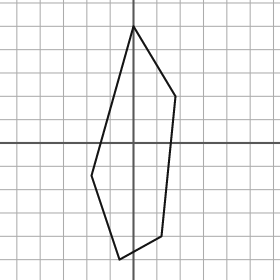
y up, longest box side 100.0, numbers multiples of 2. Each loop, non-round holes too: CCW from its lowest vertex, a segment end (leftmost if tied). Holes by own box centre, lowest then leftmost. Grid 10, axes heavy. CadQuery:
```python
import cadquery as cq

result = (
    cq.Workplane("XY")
    .moveTo(-6.0, -50.0)
    .lineTo(12.0, -40.0)
    .lineTo(18.0, 20.0)
    .lineTo(0.0, 50.0)
    .lineTo(-18.0, -14.0)
    .close()
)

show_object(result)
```